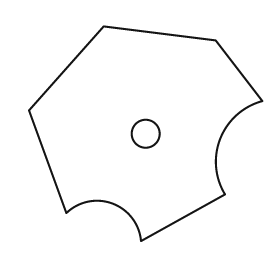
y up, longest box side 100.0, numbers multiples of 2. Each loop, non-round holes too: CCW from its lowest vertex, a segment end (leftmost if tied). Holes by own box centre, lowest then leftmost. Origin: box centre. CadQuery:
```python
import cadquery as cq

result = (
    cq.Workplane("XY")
    .moveTo(-2.0, -46.0)
    .lineTo(34.0, -26.0)
    .threePointArc((32.0, -2.0), (50.0, 14.0))
    .lineTo(30.0, 40.0)
    .lineTo(-18.0, 46.0)
    .lineTo(-50.0, 10.0)
    .lineTo(-34.0, -34.0)
    .threePointArc((-14.0, -30.0), (-2.0, -46.0))
    .close()
    .moveTo(0.0, 0.0)
    .circle(6.0)
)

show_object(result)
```